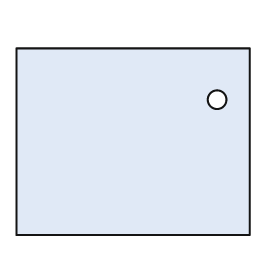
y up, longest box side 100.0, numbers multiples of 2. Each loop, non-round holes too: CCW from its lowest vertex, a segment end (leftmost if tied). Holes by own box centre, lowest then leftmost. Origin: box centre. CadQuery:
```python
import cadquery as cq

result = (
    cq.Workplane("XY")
    .moveTo(-50.0, -40.0)
    .lineTo(50.0, -40.0)
    .lineTo(50.0, 40.0)
    .lineTo(-50.0, 40.0)
    .close()
    .moveTo(36.0, 18.0)
    .circle(4.0)
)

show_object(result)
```